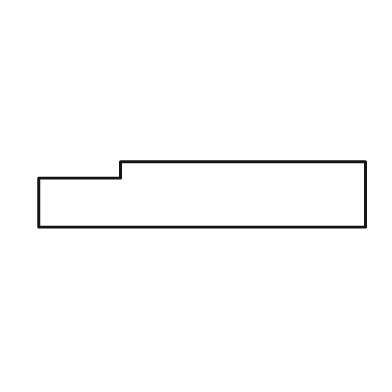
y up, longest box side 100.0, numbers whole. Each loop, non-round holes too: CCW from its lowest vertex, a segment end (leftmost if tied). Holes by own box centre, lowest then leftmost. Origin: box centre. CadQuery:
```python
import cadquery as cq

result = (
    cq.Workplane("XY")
    .moveTo(-50.0, -10.0)
    .lineTo(50.0, -10.0)
    .lineTo(50.0, 10.0)
    .lineTo(-25.0, 10.0)
    .lineTo(-25.0, 5.0)
    .lineTo(-50.0, 5.0)
    .close()
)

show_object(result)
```